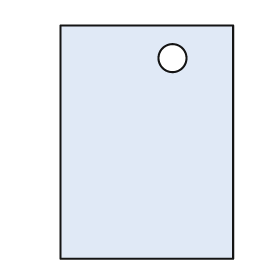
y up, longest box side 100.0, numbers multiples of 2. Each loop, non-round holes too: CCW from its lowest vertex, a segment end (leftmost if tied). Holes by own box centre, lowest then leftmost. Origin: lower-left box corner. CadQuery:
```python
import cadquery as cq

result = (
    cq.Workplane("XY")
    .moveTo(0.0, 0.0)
    .lineTo(74.0, 0.0)
    .lineTo(74.0, 100.0)
    .lineTo(0.0, 100.0)
    .close()
    .moveTo(48.0, 86.0)
    .circle(6.0)
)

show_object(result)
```